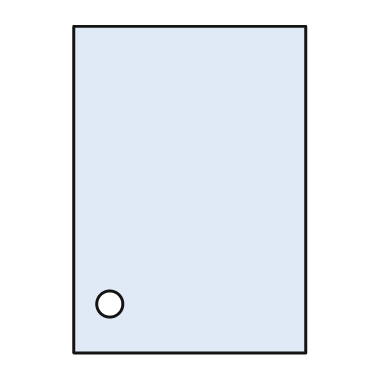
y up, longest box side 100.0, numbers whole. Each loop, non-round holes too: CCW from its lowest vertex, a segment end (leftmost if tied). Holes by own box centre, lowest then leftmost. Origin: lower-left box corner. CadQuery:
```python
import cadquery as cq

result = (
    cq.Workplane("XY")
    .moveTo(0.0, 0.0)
    .lineTo(71.0, 0.0)
    .lineTo(71.0, 100.0)
    .lineTo(0.0, 100.0)
    .close()
    .moveTo(11.0, 15.0)
    .circle(4.0)
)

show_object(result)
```